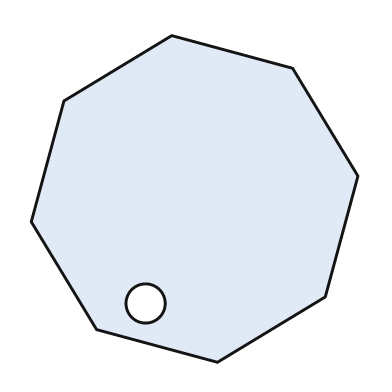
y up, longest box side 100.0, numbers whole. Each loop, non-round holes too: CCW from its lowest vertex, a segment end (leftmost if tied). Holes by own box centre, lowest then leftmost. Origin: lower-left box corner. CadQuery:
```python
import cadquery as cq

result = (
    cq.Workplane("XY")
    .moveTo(57.0, 0.0)
    .lineTo(90.0, 20.0)
    .lineTo(100.0, 57.0)
    .lineTo(80.0, 90.0)
    .lineTo(43.0, 100.0)
    .lineTo(10.0, 80.0)
    .lineTo(0.0, 43.0)
    .lineTo(20.0, 10.0)
    .close()
    .moveTo(35.0, 18.0)
    .circle(6.0)
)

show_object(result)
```